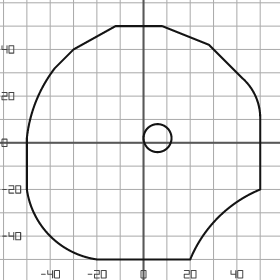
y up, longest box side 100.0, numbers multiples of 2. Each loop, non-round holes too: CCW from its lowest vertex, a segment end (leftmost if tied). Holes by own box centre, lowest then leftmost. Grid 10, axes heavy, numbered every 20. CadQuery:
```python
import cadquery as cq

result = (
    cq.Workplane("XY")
    .moveTo(-20.0, -50.0)
    .lineTo(20.0, -50.0)
    .threePointArc((32.0, -32.0), (50.0, -20.0))
    .lineTo(50.0, 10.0)
    .threePointArc((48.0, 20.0), (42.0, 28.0))
    .lineTo(28.0, 42.0)
    .lineTo(8.0, 50.0)
    .lineTo(-12.0, 50.0)
    .lineTo(-30.0, 40.0)
    .lineTo(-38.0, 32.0)
    .threePointArc((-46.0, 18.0), (-50.0, 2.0))
    .lineTo(-50.0, -20.0)
    .threePointArc((-40.0, -40.0), (-20.0, -50.0))
    .close()
    .moveTo(6.0, 2.0)
    .circle(6.0)
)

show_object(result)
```